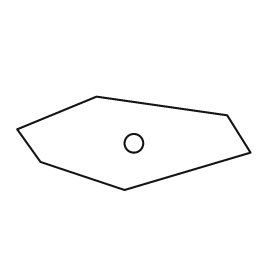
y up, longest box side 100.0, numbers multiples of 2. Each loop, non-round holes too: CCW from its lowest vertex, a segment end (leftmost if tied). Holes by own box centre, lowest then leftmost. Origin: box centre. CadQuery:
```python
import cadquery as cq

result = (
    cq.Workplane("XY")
    .moveTo(-4.0, -20.0)
    .lineTo(50.0, -4.0)
    .lineTo(40.0, 12.0)
    .lineTo(-16.0, 20.0)
    .lineTo(-50.0, 6.0)
    .lineTo(-40.0, -8.0)
    .close()
    .moveTo(0.0, 0.0)
    .circle(4.0)
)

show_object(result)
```